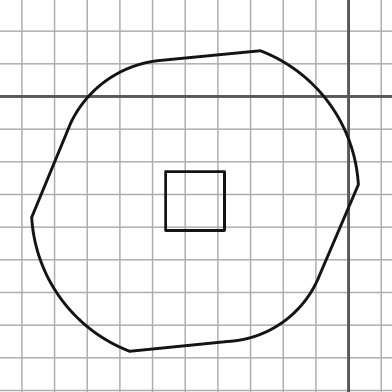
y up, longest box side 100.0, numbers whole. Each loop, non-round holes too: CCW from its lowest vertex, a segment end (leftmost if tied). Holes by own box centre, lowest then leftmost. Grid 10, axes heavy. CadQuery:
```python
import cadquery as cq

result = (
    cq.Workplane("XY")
    .moveTo(-67.0, -78.0)
    .lineTo(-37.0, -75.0)
    .threePointArc((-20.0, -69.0), (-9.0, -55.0))
    .lineTo(3.0, -27.0)
    .threePointArc((-6.0, -2.0), (-27.0, 14.0))
    .lineTo(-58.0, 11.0)
    .threePointArc((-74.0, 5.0), (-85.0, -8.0))
    .lineTo(-97.0, -37.0)
    .threePointArc((-88.0, -62.0), (-67.0, -78.0))
    .close()
    .moveTo(-56.0, -41.0)
    .lineTo(-38.0, -41.0)
    .lineTo(-38.0, -23.0)
    .lineTo(-56.0, -23.0)
    .close()
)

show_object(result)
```